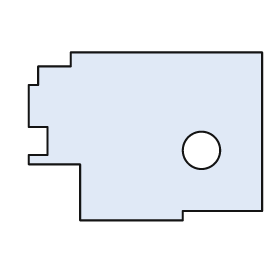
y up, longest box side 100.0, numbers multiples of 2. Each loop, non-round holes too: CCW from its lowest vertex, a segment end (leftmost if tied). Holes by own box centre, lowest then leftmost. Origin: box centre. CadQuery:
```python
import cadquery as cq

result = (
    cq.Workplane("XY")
    .moveTo(-28.0, -36.0)
    .lineTo(16.0, -36.0)
    .lineTo(16.0, -32.0)
    .lineTo(50.0, -32.0)
    .lineTo(50.0, 36.0)
    .lineTo(-32.0, 36.0)
    .lineTo(-32.0, 30.0)
    .lineTo(-46.0, 30.0)
    .lineTo(-46.0, 22.0)
    .lineTo(-50.0, 22.0)
    .lineTo(-50.0, 4.0)
    .lineTo(-42.0, 4.0)
    .lineTo(-42.0, -8.0)
    .lineTo(-50.0, -8.0)
    .lineTo(-50.0, -12.0)
    .lineTo(-28.0, -12.0)
    .close()
    .moveTo(24.0, -6.0)
    .circle(8.0)
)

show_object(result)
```